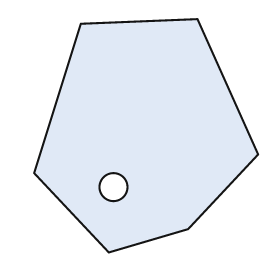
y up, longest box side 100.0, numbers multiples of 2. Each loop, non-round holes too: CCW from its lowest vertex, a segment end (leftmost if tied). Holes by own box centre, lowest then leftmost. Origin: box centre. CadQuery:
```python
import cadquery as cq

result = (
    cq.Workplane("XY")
    .moveTo(-16.0, -50.0)
    .lineTo(18.0, -40.0)
    .lineTo(48.0, -8.0)
    .lineTo(22.0, 50.0)
    .lineTo(-28.0, 48.0)
    .lineTo(-48.0, -16.0)
    .close()
    .moveTo(-14.0, -22.0)
    .circle(6.0)
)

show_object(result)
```